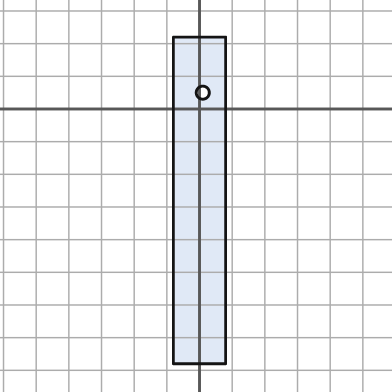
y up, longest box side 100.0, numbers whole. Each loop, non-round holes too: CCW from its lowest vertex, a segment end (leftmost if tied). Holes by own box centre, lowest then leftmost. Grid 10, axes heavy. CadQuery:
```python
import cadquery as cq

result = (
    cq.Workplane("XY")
    .moveTo(-8.0, -78.0)
    .lineTo(8.0, -78.0)
    .lineTo(8.0, 22.0)
    .lineTo(-8.0, 22.0)
    .close()
    .moveTo(1.0, 5.0)
    .circle(2.0)
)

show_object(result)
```